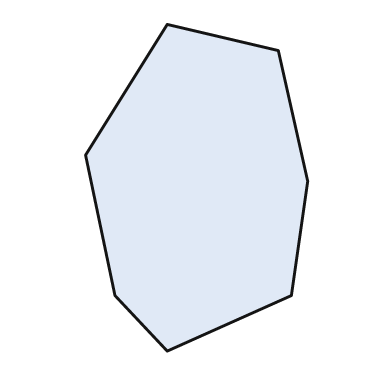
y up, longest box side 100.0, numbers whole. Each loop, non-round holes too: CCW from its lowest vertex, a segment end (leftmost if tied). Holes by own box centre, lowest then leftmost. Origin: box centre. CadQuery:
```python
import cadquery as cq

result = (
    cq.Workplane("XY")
    .moveTo(-9.0, -50.0)
    .lineTo(29.0, -33.0)
    .lineTo(34.0, 2.0)
    .lineTo(25.0, 42.0)
    .lineTo(-9.0, 50.0)
    .lineTo(-34.0, 10.0)
    .lineTo(-25.0, -33.0)
    .close()
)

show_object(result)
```